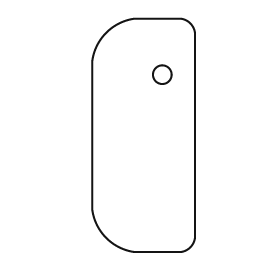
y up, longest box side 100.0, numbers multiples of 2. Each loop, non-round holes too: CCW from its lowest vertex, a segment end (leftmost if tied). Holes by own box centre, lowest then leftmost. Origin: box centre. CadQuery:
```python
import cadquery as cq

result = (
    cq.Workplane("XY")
    .moveTo(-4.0, -50.0)
    .lineTo(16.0, -50.0)
    .threePointArc((20.0, -48.0), (22.0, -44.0))
    .lineTo(22.0, 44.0)
    .threePointArc((20.0, 48.0), (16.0, 50.0))
    .lineTo(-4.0, 50.0)
    .threePointArc((-16.0, 44.0), (-22.0, 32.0))
    .lineTo(-22.0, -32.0)
    .threePointArc((-16.0, -44.0), (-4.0, -50.0))
    .close()
    .moveTo(8.0, 26.0)
    .circle(4.0)
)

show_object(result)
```